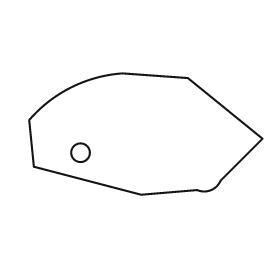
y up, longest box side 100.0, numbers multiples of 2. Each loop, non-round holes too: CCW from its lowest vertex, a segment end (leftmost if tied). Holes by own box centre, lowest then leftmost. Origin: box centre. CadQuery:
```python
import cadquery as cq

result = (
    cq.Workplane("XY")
    .moveTo(-2.0, -26.0)
    .lineTo(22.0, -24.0)
    .threePointArc((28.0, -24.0), (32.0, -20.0))
    .lineTo(50.0, -2.0)
    .lineTo(18.0, 24.0)
    .lineTo(-10.0, 26.0)
    .threePointArc((-32.0, 20.0), (-50.0, 6.0))
    .lineTo(-48.0, -14.0)
    .close()
    .moveTo(-28.0, -8.0)
    .circle(4.0)
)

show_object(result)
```